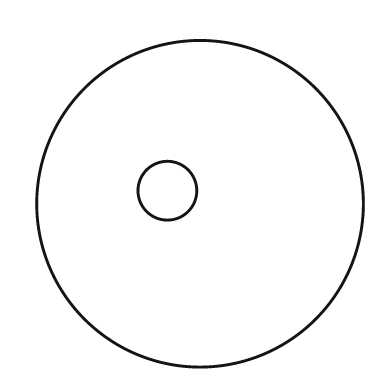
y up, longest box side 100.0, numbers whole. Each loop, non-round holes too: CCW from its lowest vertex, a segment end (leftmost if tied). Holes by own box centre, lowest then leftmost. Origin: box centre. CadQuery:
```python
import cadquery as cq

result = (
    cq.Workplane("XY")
    .moveTo(0.0, 0.0)
    .circle(50.0)
    .moveTo(-10.0, 4.0)
    .circle(9.0)
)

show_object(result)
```